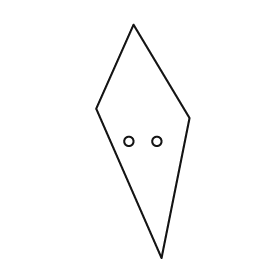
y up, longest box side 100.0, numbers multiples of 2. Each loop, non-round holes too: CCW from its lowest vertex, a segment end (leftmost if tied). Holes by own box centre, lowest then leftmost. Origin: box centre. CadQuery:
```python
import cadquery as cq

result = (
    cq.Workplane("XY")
    .moveTo(8.0, -50.0)
    .lineTo(20.0, 10.0)
    .lineTo(-4.0, 50.0)
    .lineTo(-20.0, 14.0)
    .close()
    .moveTo(-6.0, 0.0)
    .circle(2.0)
    .moveTo(6.0, 0.0)
    .circle(2.0)
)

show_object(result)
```